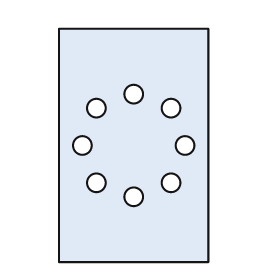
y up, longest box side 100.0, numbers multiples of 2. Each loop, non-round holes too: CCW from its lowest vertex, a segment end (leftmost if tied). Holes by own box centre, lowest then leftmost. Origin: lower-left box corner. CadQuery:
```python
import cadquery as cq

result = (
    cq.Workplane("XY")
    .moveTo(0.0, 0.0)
    .lineTo(64.0, 0.0)
    .lineTo(64.0, 100.0)
    .lineTo(0.0, 100.0)
    .close()
    .moveTo(32.0, 28.0)
    .circle(4.0)
    .moveTo(16.0, 34.0)
    .circle(4.0)
    .moveTo(48.0, 34.0)
    .circle(4.0)
    .moveTo(10.0, 50.0)
    .circle(4.0)
    .moveTo(54.0, 50.0)
    .circle(4.0)
    .moveTo(16.0, 66.0)
    .circle(4.0)
    .moveTo(48.0, 66.0)
    .circle(4.0)
    .moveTo(32.0, 72.0)
    .circle(4.0)
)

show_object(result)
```